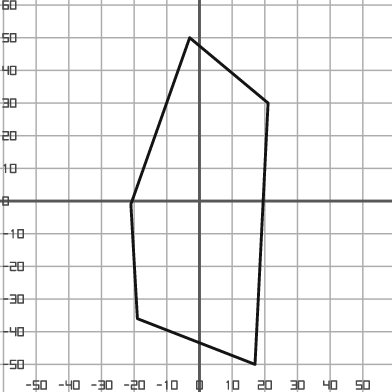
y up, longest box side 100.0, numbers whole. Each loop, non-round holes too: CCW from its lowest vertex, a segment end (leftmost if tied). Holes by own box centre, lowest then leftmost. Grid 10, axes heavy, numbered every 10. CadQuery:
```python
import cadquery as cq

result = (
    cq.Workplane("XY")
    .moveTo(17.0, -50.0)
    .lineTo(21.0, 30.0)
    .lineTo(-3.0, 50.0)
    .lineTo(-21.0, -1.0)
    .lineTo(-19.0, -36.0)
    .close()
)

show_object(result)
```